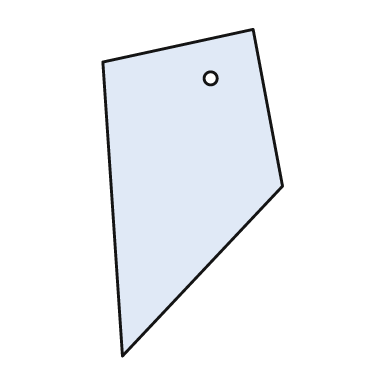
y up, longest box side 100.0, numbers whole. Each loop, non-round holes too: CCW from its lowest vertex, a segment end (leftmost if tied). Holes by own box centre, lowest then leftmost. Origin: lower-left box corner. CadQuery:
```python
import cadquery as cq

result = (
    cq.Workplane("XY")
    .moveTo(6.0, 0.0)
    .lineTo(55.0, 52.0)
    .lineTo(46.0, 100.0)
    .lineTo(0.0, 90.0)
    .close()
    .moveTo(33.0, 85.0)
    .circle(2.0)
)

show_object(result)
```